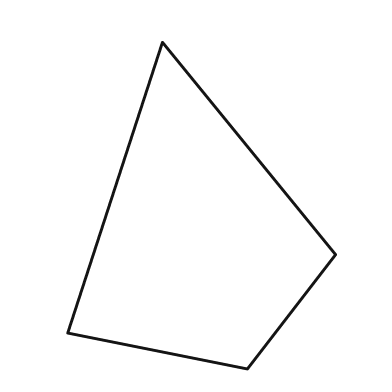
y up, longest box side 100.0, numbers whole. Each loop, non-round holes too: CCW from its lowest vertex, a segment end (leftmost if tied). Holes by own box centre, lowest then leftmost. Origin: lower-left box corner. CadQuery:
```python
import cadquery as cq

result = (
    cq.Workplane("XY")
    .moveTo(55.0, 0.0)
    .lineTo(82.0, 35.0)
    .lineTo(29.0, 100.0)
    .lineTo(0.0, 11.0)
    .close()
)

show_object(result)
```